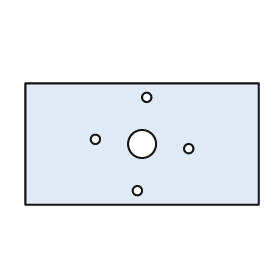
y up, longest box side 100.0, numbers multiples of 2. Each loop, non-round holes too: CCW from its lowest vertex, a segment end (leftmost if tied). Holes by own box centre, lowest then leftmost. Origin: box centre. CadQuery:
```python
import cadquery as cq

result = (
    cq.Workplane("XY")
    .moveTo(-50.0, -26.0)
    .lineTo(50.0, -26.0)
    .lineTo(50.0, 26.0)
    .lineTo(-50.0, 26.0)
    .close()
    .moveTo(-2.0, -20.0)
    .circle(2.0)
    .moveTo(20.0, -2.0)
    .circle(2.0)
    .moveTo(0.0, 0.0)
    .circle(6.0)
    .moveTo(-20.0, 2.0)
    .circle(2.0)
    .moveTo(2.0, 20.0)
    .circle(2.0)
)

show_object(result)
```